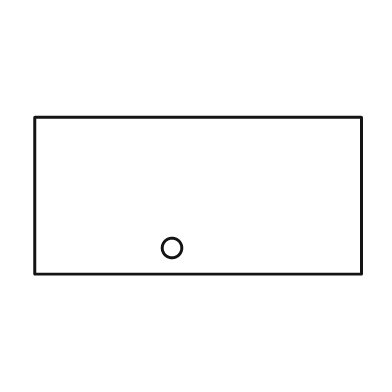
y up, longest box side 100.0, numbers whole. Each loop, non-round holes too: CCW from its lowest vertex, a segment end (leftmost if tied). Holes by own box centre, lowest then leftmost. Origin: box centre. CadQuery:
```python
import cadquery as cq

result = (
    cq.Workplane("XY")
    .moveTo(-50.0, -24.0)
    .lineTo(50.0, -24.0)
    .lineTo(50.0, 24.0)
    .lineTo(-50.0, 24.0)
    .close()
    .moveTo(-8.0, -16.0)
    .circle(3.0)
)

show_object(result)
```